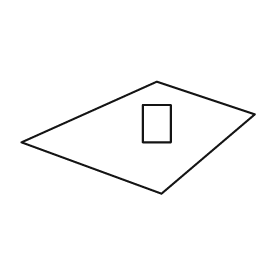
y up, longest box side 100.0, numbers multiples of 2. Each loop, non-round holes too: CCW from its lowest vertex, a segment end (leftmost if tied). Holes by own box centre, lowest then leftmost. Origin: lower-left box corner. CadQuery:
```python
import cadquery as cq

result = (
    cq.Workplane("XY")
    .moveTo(60.0, 0.0)
    .lineTo(100.0, 34.0)
    .lineTo(58.0, 48.0)
    .lineTo(0.0, 22.0)
    .close()
    .moveTo(52.0, 22.0)
    .lineTo(64.0, 22.0)
    .lineTo(64.0, 38.0)
    .lineTo(52.0, 38.0)
    .close()
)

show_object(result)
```